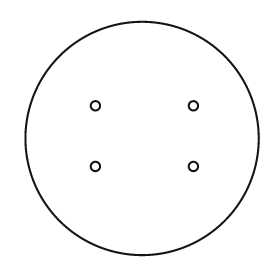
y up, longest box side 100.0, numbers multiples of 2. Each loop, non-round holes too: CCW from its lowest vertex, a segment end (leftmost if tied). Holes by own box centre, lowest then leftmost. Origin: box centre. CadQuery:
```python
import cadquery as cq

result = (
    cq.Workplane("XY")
    .moveTo(0.0, 0.0)
    .circle(50.0)
    .moveTo(-20.0, -12.0)
    .circle(2.0)
    .moveTo(22.0, -12.0)
    .circle(2.0)
    .moveTo(-20.0, 14.0)
    .circle(2.0)
    .moveTo(22.0, 14.0)
    .circle(2.0)
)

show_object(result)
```